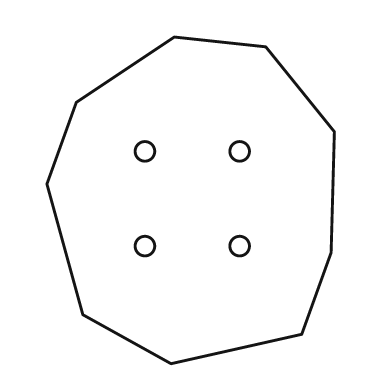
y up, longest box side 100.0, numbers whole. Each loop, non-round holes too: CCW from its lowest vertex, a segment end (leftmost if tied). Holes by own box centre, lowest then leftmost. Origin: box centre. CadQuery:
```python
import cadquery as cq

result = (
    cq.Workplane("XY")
    .moveTo(-6.0, -50.0)
    .lineTo(34.0, -41.0)
    .lineTo(43.0, -16.0)
    .lineTo(44.0, 21.0)
    .lineTo(23.0, 47.0)
    .lineTo(-5.0, 50.0)
    .lineTo(-35.0, 30.0)
    .lineTo(-44.0, 5.0)
    .lineTo(-33.0, -35.0)
    .close()
    .moveTo(-14.0, -14.0)
    .circle(3.0)
    .moveTo(15.0, -14.0)
    .circle(3.0)
    .moveTo(-14.0, 15.0)
    .circle(3.0)
    .moveTo(15.0, 15.0)
    .circle(3.0)
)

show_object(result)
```